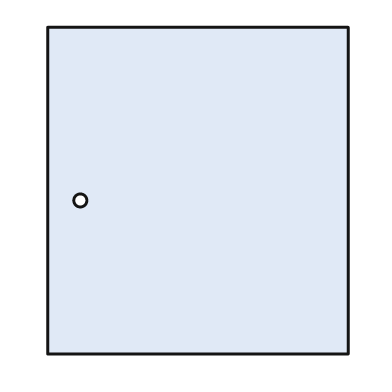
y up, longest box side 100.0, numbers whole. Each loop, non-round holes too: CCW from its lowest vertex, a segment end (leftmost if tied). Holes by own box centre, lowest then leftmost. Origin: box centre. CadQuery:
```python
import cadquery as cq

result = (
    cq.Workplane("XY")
    .moveTo(-46.0, -50.0)
    .lineTo(46.0, -50.0)
    .lineTo(46.0, 50.0)
    .lineTo(-46.0, 50.0)
    .close()
    .moveTo(-36.0, -3.0)
    .circle(2.0)
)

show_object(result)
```